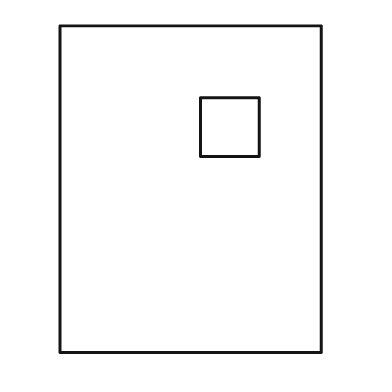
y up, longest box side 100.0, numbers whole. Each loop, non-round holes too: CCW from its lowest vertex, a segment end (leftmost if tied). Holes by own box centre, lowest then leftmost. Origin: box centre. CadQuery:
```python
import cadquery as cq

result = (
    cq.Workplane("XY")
    .moveTo(-40.0, -50.0)
    .lineTo(40.0, -50.0)
    .lineTo(40.0, 50.0)
    .lineTo(-40.0, 50.0)
    .close()
    .moveTo(3.0, 10.0)
    .lineTo(21.0, 10.0)
    .lineTo(21.0, 28.0)
    .lineTo(3.0, 28.0)
    .close()
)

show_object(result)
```